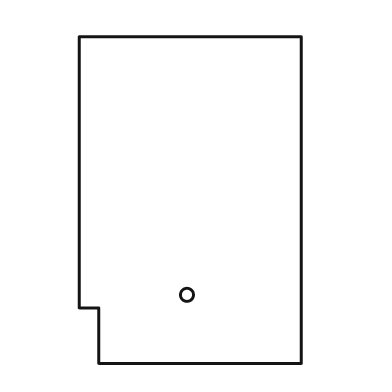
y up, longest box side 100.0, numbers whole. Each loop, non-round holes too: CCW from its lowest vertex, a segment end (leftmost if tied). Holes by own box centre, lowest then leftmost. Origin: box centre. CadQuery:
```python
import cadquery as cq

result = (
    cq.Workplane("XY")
    .moveTo(-28.0, -50.0)
    .lineTo(34.0, -50.0)
    .lineTo(34.0, 50.0)
    .lineTo(-34.0, 50.0)
    .lineTo(-34.0, -33.0)
    .lineTo(-28.0, -33.0)
    .close()
    .moveTo(-1.0, -29.0)
    .circle(2.0)
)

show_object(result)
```